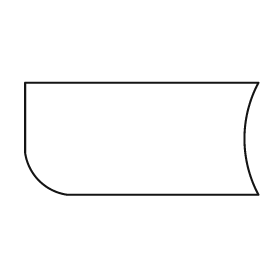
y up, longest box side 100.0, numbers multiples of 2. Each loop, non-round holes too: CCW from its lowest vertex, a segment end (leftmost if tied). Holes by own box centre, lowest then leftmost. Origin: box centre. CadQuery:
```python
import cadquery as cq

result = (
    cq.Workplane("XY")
    .moveTo(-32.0, -24.0)
    .lineTo(50.0, -24.0)
    .threePointArc((44.0, 0.0), (50.0, 24.0))
    .lineTo(-50.0, 24.0)
    .lineTo(-50.0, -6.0)
    .threePointArc((-44.0, -18.0), (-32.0, -24.0))
    .close()
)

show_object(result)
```